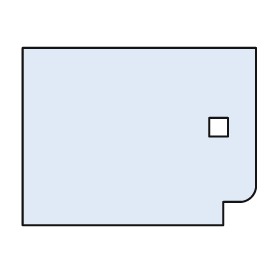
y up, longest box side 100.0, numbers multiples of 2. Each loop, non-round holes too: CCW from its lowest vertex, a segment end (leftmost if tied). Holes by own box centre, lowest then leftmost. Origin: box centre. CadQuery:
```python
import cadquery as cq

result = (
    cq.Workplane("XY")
    .moveTo(-50.0, -38.0)
    .lineTo(36.0, -38.0)
    .lineTo(36.0, -28.0)
    .lineTo(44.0, -28.0)
    .threePointArc((48.0, -26.0), (50.0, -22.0))
    .lineTo(50.0, 38.0)
    .lineTo(-50.0, 38.0)
    .close()
    .moveTo(30.0, 0.0)
    .lineTo(38.0, 0.0)
    .lineTo(38.0, 8.0)
    .lineTo(30.0, 8.0)
    .close()
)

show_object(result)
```